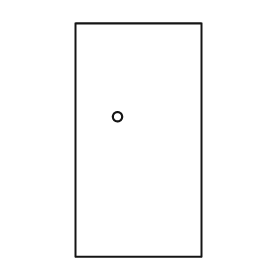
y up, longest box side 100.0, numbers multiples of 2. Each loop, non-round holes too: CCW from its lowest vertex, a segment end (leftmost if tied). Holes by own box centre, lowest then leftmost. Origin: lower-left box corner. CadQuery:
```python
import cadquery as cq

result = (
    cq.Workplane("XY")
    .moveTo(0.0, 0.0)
    .lineTo(54.0, 0.0)
    .lineTo(54.0, 100.0)
    .lineTo(0.0, 100.0)
    .close()
    .moveTo(18.0, 60.0)
    .circle(2.0)
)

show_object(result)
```